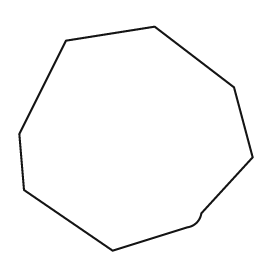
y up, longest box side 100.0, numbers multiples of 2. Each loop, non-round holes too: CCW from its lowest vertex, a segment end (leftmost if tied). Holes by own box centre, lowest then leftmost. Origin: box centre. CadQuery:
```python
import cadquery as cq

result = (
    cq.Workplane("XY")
    .moveTo(-10.0, -48.0)
    .lineTo(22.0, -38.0)
    .threePointArc((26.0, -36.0), (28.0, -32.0))
    .lineTo(50.0, -8.0)
    .lineTo(42.0, 22.0)
    .lineTo(8.0, 48.0)
    .lineTo(-30.0, 42.0)
    .lineTo(-50.0, 2.0)
    .lineTo(-48.0, -22.0)
    .close()
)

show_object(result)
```